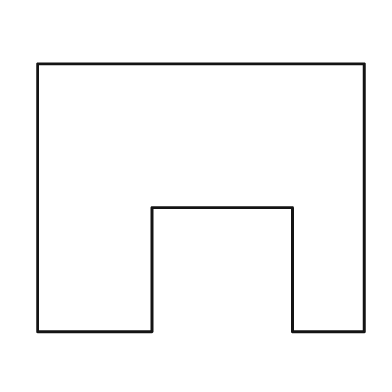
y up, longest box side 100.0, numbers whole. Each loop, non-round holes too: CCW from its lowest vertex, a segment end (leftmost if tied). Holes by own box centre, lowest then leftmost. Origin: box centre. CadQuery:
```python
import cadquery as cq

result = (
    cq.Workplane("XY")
    .moveTo(-50.0, -41.0)
    .lineTo(-15.0, -41.0)
    .lineTo(-15.0, -3.0)
    .lineTo(28.0, -3.0)
    .lineTo(28.0, -41.0)
    .lineTo(50.0, -41.0)
    .lineTo(50.0, 41.0)
    .lineTo(-50.0, 41.0)
    .close()
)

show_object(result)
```